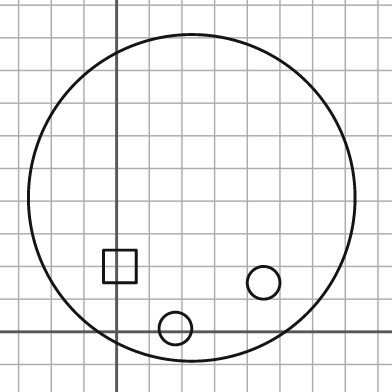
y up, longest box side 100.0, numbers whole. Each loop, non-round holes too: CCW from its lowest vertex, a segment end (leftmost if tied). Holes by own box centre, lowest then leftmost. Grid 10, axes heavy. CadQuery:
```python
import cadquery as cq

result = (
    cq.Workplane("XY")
    .moveTo(23.0, 41.0)
    .circle(50.0)
    .moveTo(18.0, 1.0)
    .circle(5.0)
    .moveTo(45.0, 15.0)
    .circle(5.0)
    .moveTo(-4.0, 15.0)
    .lineTo(6.0, 15.0)
    .lineTo(6.0, 25.0)
    .lineTo(-4.0, 25.0)
    .close()
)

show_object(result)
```